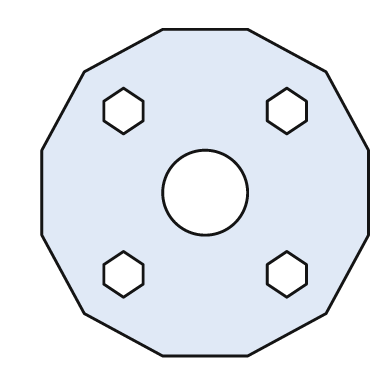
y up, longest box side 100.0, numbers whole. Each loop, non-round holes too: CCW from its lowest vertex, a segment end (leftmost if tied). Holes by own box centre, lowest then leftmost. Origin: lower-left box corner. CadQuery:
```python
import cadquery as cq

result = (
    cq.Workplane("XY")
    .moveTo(37.0, 0.0)
    .lineTo(63.0, 0.0)
    .lineTo(87.0, 13.0)
    .lineTo(100.0, 37.0)
    .lineTo(100.0, 63.0)
    .lineTo(87.0, 87.0)
    .lineTo(63.0, 100.0)
    .lineTo(37.0, 100.0)
    .lineTo(13.0, 87.0)
    .lineTo(0.0, 63.0)
    .lineTo(0.0, 37.0)
    .lineTo(13.0, 13.0)
    .close()
    .moveTo(25.0, 18.0)
    .lineTo(31.0, 22.0)
    .lineTo(31.0, 28.0)
    .lineTo(25.0, 32.0)
    .lineTo(19.0, 28.0)
    .lineTo(19.0, 22.0)
    .close()
    .moveTo(75.0, 18.0)
    .lineTo(81.0, 22.0)
    .lineTo(81.0, 28.0)
    .lineTo(75.0, 32.0)
    .lineTo(69.0, 28.0)
    .lineTo(69.0, 22.0)
    .close()
    .moveTo(50.0, 50.0)
    .circle(13.0)
    .moveTo(25.0, 68.0)
    .lineTo(31.0, 72.0)
    .lineTo(31.0, 78.0)
    .lineTo(25.0, 82.0)
    .lineTo(19.0, 78.0)
    .lineTo(19.0, 72.0)
    .close()
    .moveTo(75.0, 68.0)
    .lineTo(81.0, 72.0)
    .lineTo(81.0, 78.0)
    .lineTo(75.0, 82.0)
    .lineTo(69.0, 78.0)
    .lineTo(69.0, 72.0)
    .close()
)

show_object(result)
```